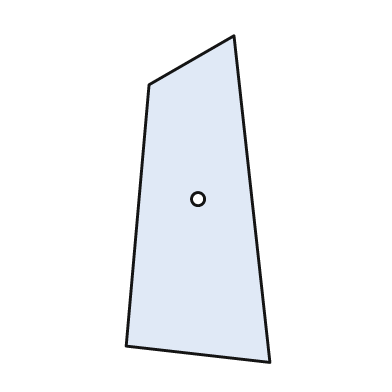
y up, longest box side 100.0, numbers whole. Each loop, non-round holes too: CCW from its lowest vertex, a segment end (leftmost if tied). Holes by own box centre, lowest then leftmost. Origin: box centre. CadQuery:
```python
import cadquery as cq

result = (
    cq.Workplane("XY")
    .moveTo(22.0, -50.0)
    .lineTo(11.0, 50.0)
    .lineTo(-15.0, 35.0)
    .lineTo(-22.0, -45.0)
    .close()
    .moveTo(0.0, 0.0)
    .circle(2.0)
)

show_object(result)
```